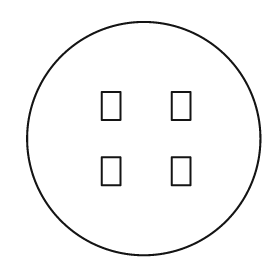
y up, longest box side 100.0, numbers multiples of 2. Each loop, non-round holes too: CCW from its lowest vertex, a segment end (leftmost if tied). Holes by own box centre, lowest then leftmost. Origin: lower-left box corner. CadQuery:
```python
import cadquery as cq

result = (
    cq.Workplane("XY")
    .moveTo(50.0, 50.0)
    .circle(50.0)
    .moveTo(32.0, 30.0)
    .lineTo(40.0, 30.0)
    .lineTo(40.0, 42.0)
    .lineTo(32.0, 42.0)
    .close()
    .moveTo(62.0, 30.0)
    .lineTo(70.0, 30.0)
    .lineTo(70.0, 42.0)
    .lineTo(62.0, 42.0)
    .close()
    .moveTo(32.0, 58.0)
    .lineTo(40.0, 58.0)
    .lineTo(40.0, 70.0)
    .lineTo(32.0, 70.0)
    .close()
    .moveTo(62.0, 58.0)
    .lineTo(70.0, 58.0)
    .lineTo(70.0, 70.0)
    .lineTo(62.0, 70.0)
    .close()
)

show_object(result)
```